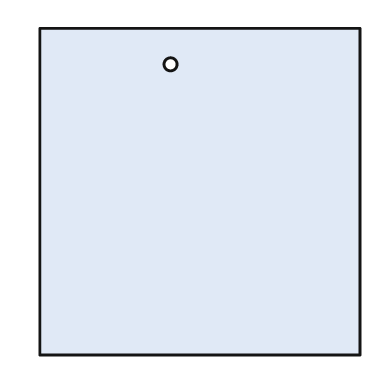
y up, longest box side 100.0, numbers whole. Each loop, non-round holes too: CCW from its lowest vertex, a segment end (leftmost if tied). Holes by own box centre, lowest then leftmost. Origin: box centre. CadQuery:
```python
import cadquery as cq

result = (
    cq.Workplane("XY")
    .moveTo(-49.0, -50.0)
    .lineTo(49.0, -50.0)
    .lineTo(49.0, 50.0)
    .lineTo(-49.0, 50.0)
    .close()
    .moveTo(-9.0, 39.0)
    .circle(2.0)
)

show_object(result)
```